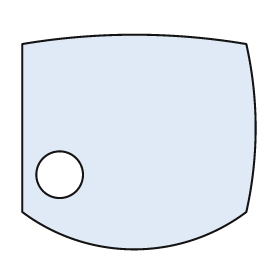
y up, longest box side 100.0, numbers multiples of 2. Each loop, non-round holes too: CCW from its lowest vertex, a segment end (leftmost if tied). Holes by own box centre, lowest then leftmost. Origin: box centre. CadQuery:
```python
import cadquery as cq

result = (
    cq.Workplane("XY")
    .moveTo(-50.0, -30.0)
    .threePointArc((-2.0, -46.0), (46.0, -30.0))
    .threePointArc((50.0, 6.0), (46.0, 42.0))
    .threePointArc((-2.0, 46.0), (-50.0, 42.0))
    .close()
    .moveTo(-34.0, -14.0)
    .circle(10.0)
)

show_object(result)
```